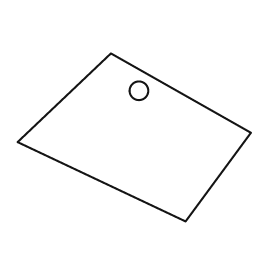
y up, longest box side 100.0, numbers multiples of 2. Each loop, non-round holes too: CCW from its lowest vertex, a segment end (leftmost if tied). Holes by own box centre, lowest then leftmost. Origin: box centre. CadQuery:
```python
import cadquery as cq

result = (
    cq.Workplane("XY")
    .moveTo(22.0, -36.0)
    .lineTo(50.0, 2.0)
    .lineTo(-10.0, 36.0)
    .lineTo(-50.0, -2.0)
    .close()
    .moveTo(2.0, 20.0)
    .circle(4.0)
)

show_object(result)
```